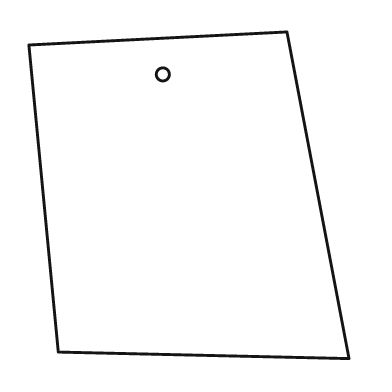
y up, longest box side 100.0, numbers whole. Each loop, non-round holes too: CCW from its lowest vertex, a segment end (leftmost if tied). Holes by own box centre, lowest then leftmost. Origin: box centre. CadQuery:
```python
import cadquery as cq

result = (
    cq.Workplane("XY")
    .moveTo(49.0, -50.0)
    .lineTo(30.0, 50.0)
    .lineTo(-49.0, 46.0)
    .lineTo(-40.0, -48.0)
    .close()
    .moveTo(-8.0, 37.0)
    .circle(2.0)
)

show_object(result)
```